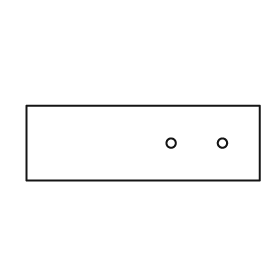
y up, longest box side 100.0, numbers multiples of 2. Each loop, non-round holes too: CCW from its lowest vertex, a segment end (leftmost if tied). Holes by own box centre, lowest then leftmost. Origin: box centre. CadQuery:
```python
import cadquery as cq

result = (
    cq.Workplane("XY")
    .moveTo(-50.0, -16.0)
    .lineTo(50.0, -16.0)
    .lineTo(50.0, 16.0)
    .lineTo(-50.0, 16.0)
    .close()
    .moveTo(12.0, 0.0)
    .circle(2.0)
    .moveTo(34.0, 0.0)
    .circle(2.0)
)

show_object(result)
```